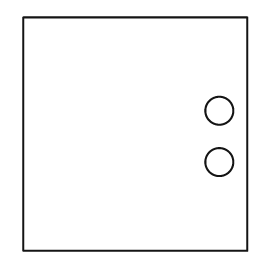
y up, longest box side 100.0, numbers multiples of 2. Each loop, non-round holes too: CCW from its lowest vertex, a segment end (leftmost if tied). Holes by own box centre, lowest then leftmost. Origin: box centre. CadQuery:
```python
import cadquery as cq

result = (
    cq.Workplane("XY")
    .moveTo(-48.0, -50.0)
    .lineTo(48.0, -50.0)
    .lineTo(48.0, 50.0)
    .lineTo(-48.0, 50.0)
    .close()
    .moveTo(36.0, -12.0)
    .circle(6.0)
    .moveTo(36.0, 10.0)
    .circle(6.0)
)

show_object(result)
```